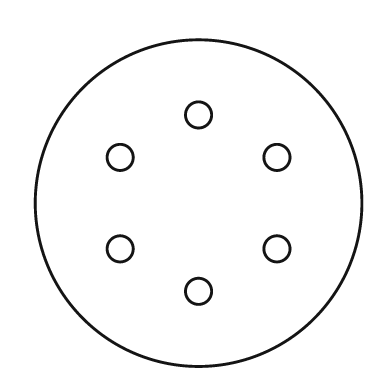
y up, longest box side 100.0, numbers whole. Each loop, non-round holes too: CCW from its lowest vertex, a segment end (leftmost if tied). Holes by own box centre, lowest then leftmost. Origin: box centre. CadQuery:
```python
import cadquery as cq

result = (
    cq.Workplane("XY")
    .moveTo(0.0, 0.0)
    .circle(50.0)
    .moveTo(0.0, -27.0)
    .circle(4.0)
    .moveTo(-24.0, -14.0)
    .circle(4.0)
    .moveTo(24.0, -14.0)
    .circle(4.0)
    .moveTo(-24.0, 14.0)
    .circle(4.0)
    .moveTo(24.0, 14.0)
    .circle(4.0)
    .moveTo(0.0, 27.0)
    .circle(4.0)
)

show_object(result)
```